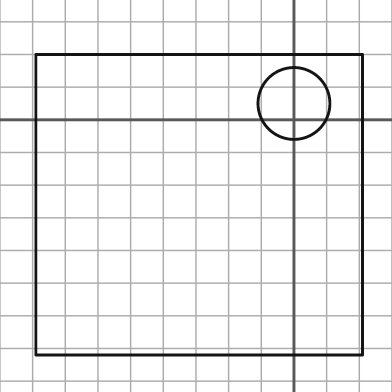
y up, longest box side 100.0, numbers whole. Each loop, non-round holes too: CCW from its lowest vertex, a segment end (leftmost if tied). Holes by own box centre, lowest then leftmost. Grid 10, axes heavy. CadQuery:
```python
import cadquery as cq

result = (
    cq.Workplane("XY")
    .moveTo(-79.0, -72.0)
    .lineTo(21.0, -72.0)
    .lineTo(21.0, 20.0)
    .lineTo(-79.0, 20.0)
    .close()
    .moveTo(0.0, 5.0)
    .circle(11.0)
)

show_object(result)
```